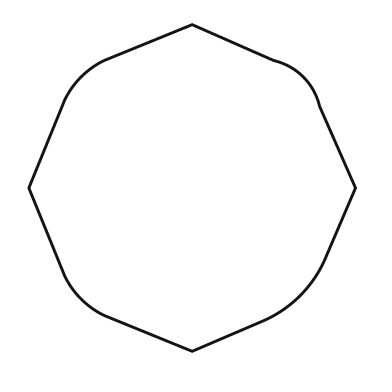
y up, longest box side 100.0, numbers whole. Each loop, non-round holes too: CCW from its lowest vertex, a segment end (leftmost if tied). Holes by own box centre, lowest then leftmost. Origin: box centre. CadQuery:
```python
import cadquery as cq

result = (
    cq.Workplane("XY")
    .moveTo(0.0, -50.0)
    .lineTo(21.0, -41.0)
    .threePointArc((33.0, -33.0), (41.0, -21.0))
    .lineTo(50.0, 0.0)
    .lineTo(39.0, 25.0)
    .threePointArc((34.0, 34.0), (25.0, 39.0))
    .lineTo(0.0, 50.0)
    .lineTo(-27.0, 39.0)
    .threePointArc((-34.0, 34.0), (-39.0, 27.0))
    .lineTo(-50.0, 0.0)
    .lineTo(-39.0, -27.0)
    .threePointArc((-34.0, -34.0), (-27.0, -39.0))
    .close()
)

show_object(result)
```